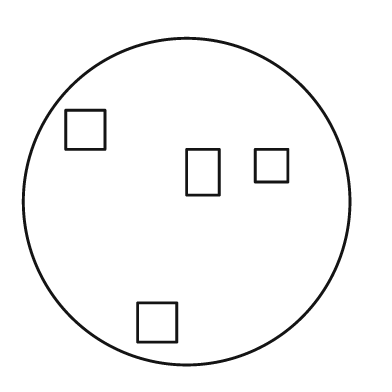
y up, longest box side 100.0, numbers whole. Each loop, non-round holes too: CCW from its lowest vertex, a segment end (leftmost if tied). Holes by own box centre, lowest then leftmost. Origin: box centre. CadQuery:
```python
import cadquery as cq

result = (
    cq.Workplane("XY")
    .moveTo(0.0, 0.0)
    .circle(50.0)
    .moveTo(-15.0, -43.0)
    .lineTo(-3.0, -43.0)
    .lineTo(-3.0, -31.0)
    .lineTo(-15.0, -31.0)
    .close()
    .moveTo(0.0, 2.0)
    .lineTo(10.0, 2.0)
    .lineTo(10.0, 16.0)
    .lineTo(0.0, 16.0)
    .close()
    .moveTo(21.0, 6.0)
    .lineTo(31.0, 6.0)
    .lineTo(31.0, 16.0)
    .lineTo(21.0, 16.0)
    .close()
    .moveTo(-37.0, 16.0)
    .lineTo(-25.0, 16.0)
    .lineTo(-25.0, 28.0)
    .lineTo(-37.0, 28.0)
    .close()
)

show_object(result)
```